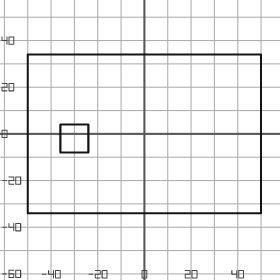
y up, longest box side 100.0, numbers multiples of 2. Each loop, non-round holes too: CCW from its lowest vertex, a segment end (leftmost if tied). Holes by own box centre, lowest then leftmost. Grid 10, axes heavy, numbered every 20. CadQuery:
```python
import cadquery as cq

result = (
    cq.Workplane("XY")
    .moveTo(-50.0, -34.0)
    .lineTo(50.0, -34.0)
    .lineTo(50.0, 34.0)
    .lineTo(-50.0, 34.0)
    .close()
    .moveTo(-36.0, -8.0)
    .lineTo(-24.0, -8.0)
    .lineTo(-24.0, 4.0)
    .lineTo(-36.0, 4.0)
    .close()
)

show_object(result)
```